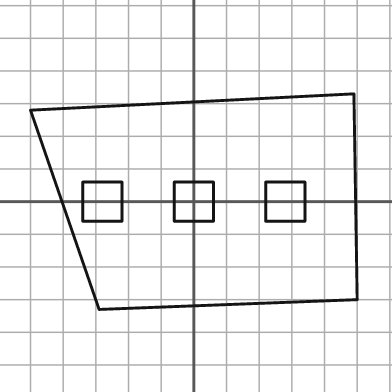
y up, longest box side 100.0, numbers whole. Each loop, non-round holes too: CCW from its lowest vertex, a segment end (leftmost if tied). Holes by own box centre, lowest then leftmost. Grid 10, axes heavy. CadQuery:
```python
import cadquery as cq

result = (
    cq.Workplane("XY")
    .moveTo(-29.0, -33.0)
    .lineTo(50.0, -30.0)
    .lineTo(49.0, 33.0)
    .lineTo(-50.0, 28.0)
    .close()
    .moveTo(-34.0, -6.0)
    .lineTo(-22.0, -6.0)
    .lineTo(-22.0, 6.0)
    .lineTo(-34.0, 6.0)
    .close()
    .moveTo(-6.0, -6.0)
    .lineTo(6.0, -6.0)
    .lineTo(6.0, 6.0)
    .lineTo(-6.0, 6.0)
    .close()
    .moveTo(22.0, -6.0)
    .lineTo(34.0, -6.0)
    .lineTo(34.0, 6.0)
    .lineTo(22.0, 6.0)
    .close()
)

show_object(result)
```